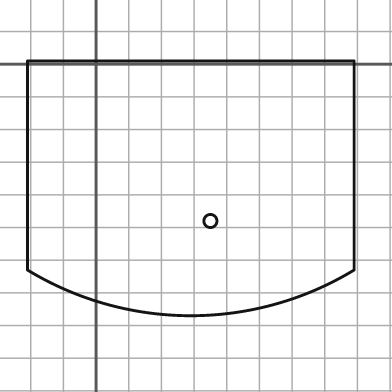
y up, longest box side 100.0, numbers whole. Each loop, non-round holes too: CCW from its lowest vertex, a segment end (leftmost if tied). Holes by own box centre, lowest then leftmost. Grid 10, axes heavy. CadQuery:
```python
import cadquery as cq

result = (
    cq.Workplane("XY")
    .moveTo(-21.0, -63.0)
    .threePointArc((29.0, -77.0), (79.0, -63.0))
    .lineTo(79.0, 1.0)
    .lineTo(-21.0, 1.0)
    .close()
    .moveTo(35.0, -48.0)
    .circle(2.0)
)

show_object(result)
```